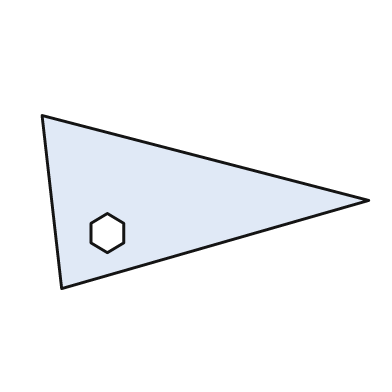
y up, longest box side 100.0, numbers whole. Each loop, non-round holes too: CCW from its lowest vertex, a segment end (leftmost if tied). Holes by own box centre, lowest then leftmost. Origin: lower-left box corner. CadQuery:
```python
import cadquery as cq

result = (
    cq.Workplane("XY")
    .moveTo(6.0, 0.0)
    .lineTo(100.0, 27.0)
    .lineTo(0.0, 53.0)
    .close()
    .moveTo(20.0, 11.0)
    .lineTo(25.0, 14.0)
    .lineTo(25.0, 20.0)
    .lineTo(20.0, 23.0)
    .lineTo(15.0, 20.0)
    .lineTo(15.0, 14.0)
    .close()
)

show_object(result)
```